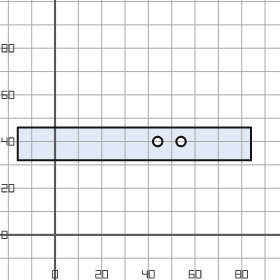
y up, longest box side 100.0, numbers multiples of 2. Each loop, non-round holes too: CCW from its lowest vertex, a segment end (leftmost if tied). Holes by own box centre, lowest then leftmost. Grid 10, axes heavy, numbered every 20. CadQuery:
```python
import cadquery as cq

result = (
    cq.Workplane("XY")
    .moveTo(-16.0, 32.0)
    .lineTo(84.0, 32.0)
    .lineTo(84.0, 46.0)
    .lineTo(-16.0, 46.0)
    .close()
    .moveTo(44.0, 40.0)
    .circle(2.0)
    .moveTo(54.0, 40.0)
    .circle(2.0)
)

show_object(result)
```